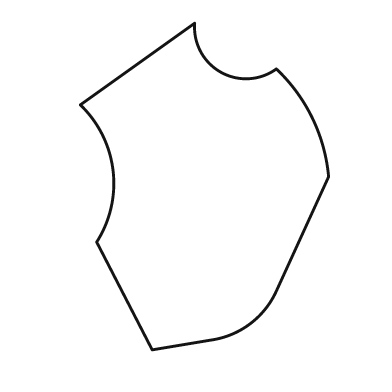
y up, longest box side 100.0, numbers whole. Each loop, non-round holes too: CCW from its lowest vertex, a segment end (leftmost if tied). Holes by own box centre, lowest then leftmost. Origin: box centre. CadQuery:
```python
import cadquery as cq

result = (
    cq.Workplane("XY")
    .moveTo(-16.0, -50.0)
    .lineTo(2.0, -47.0)
    .threePointArc((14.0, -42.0), (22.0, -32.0))
    .lineTo(38.0, 3.0)
    .threePointArc((33.0, 21.0), (22.0, 36.0))
    .threePointArc((5.0, 35.0), (-3.0, 50.0))
    .lineTo(-38.0, 25.0)
    .threePointArc((-28.0, 5.0), (-33.0, -17.0))
    .close()
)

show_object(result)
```